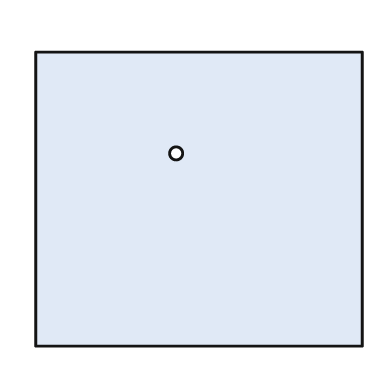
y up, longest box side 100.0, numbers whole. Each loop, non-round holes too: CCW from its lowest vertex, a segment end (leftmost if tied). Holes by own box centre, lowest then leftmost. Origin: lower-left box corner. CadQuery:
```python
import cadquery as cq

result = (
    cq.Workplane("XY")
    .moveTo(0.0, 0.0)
    .lineTo(100.0, 0.0)
    .lineTo(100.0, 90.0)
    .lineTo(0.0, 90.0)
    .close()
    .moveTo(43.0, 59.0)
    .circle(2.0)
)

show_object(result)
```